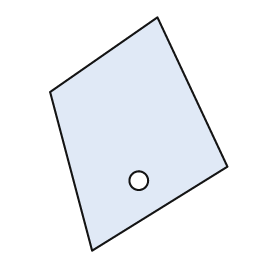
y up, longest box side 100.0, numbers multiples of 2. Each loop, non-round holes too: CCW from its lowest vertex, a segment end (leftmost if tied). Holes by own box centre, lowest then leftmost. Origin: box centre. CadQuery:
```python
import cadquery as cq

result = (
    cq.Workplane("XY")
    .moveTo(-20.0, -50.0)
    .lineTo(38.0, -14.0)
    .lineTo(8.0, 50.0)
    .lineTo(-38.0, 18.0)
    .close()
    .moveTo(0.0, -20.0)
    .circle(4.0)
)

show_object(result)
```